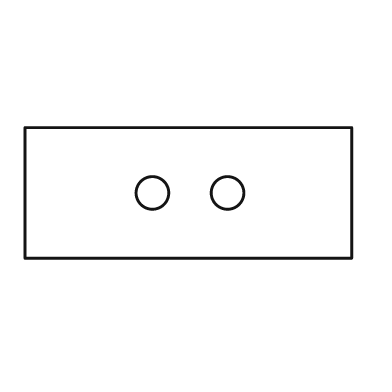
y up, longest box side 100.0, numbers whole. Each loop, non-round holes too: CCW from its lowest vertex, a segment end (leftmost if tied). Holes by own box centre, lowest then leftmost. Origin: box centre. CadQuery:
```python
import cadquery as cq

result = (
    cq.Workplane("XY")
    .moveTo(-50.0, -20.0)
    .lineTo(50.0, -20.0)
    .lineTo(50.0, 20.0)
    .lineTo(-50.0, 20.0)
    .close()
    .moveTo(-11.0, 0.0)
    .circle(5.0)
    .moveTo(12.0, 0.0)
    .circle(5.0)
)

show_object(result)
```